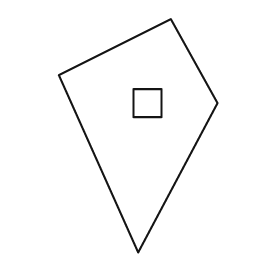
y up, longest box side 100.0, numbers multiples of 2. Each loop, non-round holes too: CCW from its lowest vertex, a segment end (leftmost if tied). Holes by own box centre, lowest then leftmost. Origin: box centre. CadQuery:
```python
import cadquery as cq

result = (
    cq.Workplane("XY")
    .moveTo(0.0, -50.0)
    .lineTo(34.0, 14.0)
    .lineTo(14.0, 50.0)
    .lineTo(-34.0, 26.0)
    .close()
    .moveTo(-2.0, 8.0)
    .lineTo(10.0, 8.0)
    .lineTo(10.0, 20.0)
    .lineTo(-2.0, 20.0)
    .close()
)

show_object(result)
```